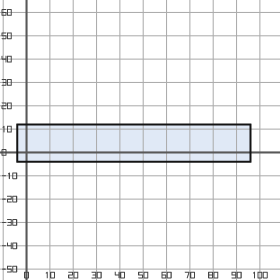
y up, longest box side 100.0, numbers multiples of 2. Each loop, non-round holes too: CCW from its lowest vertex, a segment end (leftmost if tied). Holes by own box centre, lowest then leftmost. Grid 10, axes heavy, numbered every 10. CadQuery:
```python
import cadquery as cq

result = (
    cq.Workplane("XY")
    .moveTo(-4.0, -4.0)
    .lineTo(96.0, -4.0)
    .lineTo(96.0, 12.0)
    .lineTo(-4.0, 12.0)
    .close()
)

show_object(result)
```